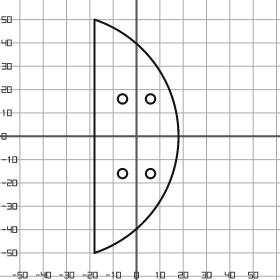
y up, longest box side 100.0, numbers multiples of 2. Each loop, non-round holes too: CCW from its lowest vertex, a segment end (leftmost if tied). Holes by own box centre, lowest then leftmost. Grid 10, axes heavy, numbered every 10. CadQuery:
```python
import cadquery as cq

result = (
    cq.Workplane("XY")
    .moveTo(-18.0, -50.0)
    .threePointArc((18.0, 0.0), (-18.0, 50.0))
    .close()
    .moveTo(-6.0, -16.0)
    .circle(2.0)
    .moveTo(6.0, -16.0)
    .circle(2.0)
    .moveTo(-6.0, 16.0)
    .circle(2.0)
    .moveTo(6.0, 16.0)
    .circle(2.0)
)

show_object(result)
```